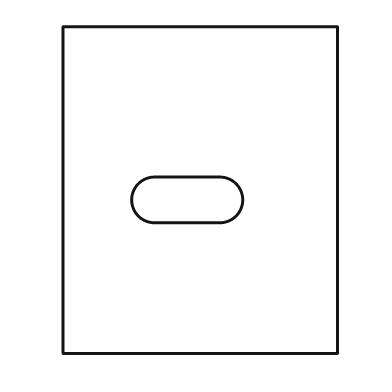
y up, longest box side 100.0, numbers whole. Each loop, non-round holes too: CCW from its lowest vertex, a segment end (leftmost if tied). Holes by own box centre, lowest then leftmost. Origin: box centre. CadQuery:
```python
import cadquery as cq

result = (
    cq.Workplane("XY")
    .moveTo(-42.0, -50.0)
    .lineTo(42.0, -50.0)
    .lineTo(42.0, 50.0)
    .lineTo(-42.0, 50.0)
    .close()
    .moveTo(-14.0, -10.0)
    .lineTo(6.0, -10.0)
    .threePointArc((13.0, -3.0), (6.0, 4.0))
    .lineTo(-14.0, 4.0)
    .threePointArc((-21.0, -3.0), (-14.0, -10.0))
    .close()
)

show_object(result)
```